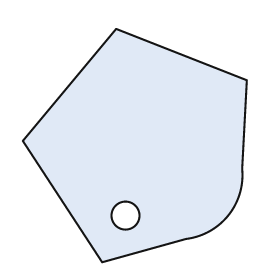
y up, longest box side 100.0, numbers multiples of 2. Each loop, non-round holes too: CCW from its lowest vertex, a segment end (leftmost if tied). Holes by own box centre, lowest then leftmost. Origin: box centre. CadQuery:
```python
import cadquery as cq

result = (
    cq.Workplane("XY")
    .moveTo(-14.0, -50.0)
    .lineTo(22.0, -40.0)
    .threePointArc((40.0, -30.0), (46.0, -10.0))
    .lineTo(48.0, 28.0)
    .lineTo(-8.0, 50.0)
    .lineTo(-48.0, 2.0)
    .close()
    .moveTo(-4.0, -30.0)
    .circle(6.0)
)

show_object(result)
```